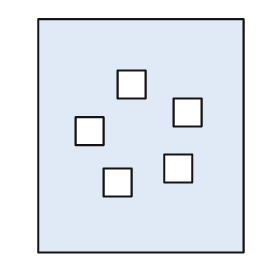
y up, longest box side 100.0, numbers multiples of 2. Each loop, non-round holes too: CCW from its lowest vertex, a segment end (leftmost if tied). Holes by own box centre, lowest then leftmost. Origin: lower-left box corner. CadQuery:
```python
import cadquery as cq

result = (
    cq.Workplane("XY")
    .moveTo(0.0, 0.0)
    .lineTo(88.0, 0.0)
    .lineTo(88.0, 100.0)
    .lineTo(0.0, 100.0)
    .close()
    .moveTo(28.0, 24.0)
    .lineTo(40.0, 24.0)
    .lineTo(40.0, 36.0)
    .lineTo(28.0, 36.0)
    .close()
    .moveTo(54.0, 30.0)
    .lineTo(66.0, 30.0)
    .lineTo(66.0, 42.0)
    .lineTo(54.0, 42.0)
    .close()
    .moveTo(16.0, 46.0)
    .lineTo(28.0, 46.0)
    .lineTo(28.0, 58.0)
    .lineTo(16.0, 58.0)
    .close()
    .moveTo(58.0, 54.0)
    .lineTo(70.0, 54.0)
    .lineTo(70.0, 66.0)
    .lineTo(58.0, 66.0)
    .close()
    .moveTo(34.0, 66.0)
    .lineTo(46.0, 66.0)
    .lineTo(46.0, 78.0)
    .lineTo(34.0, 78.0)
    .close()
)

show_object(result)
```